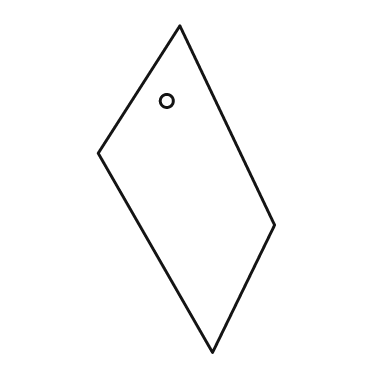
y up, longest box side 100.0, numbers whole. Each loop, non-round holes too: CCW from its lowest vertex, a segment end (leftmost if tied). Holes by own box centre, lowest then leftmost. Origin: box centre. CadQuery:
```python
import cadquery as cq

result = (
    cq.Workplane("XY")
    .moveTo(8.0, -50.0)
    .lineTo(27.0, -11.0)
    .lineTo(-2.0, 50.0)
    .lineTo(-27.0, 11.0)
    .close()
    .moveTo(-6.0, 27.0)
    .circle(2.0)
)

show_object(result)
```